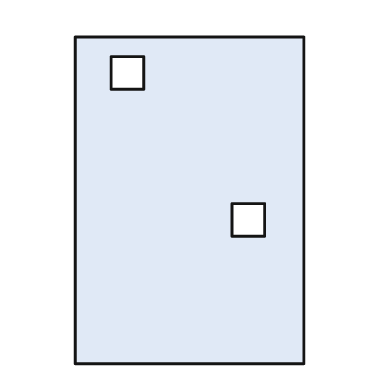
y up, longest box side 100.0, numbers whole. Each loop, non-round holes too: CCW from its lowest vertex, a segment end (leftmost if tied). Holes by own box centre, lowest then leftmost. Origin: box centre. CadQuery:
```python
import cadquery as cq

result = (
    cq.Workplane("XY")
    .moveTo(-35.0, -50.0)
    .lineTo(35.0, -50.0)
    .lineTo(35.0, 50.0)
    .lineTo(-35.0, 50.0)
    .close()
    .moveTo(13.0, -11.0)
    .lineTo(23.0, -11.0)
    .lineTo(23.0, -1.0)
    .lineTo(13.0, -1.0)
    .close()
    .moveTo(-24.0, 34.0)
    .lineTo(-14.0, 34.0)
    .lineTo(-14.0, 44.0)
    .lineTo(-24.0, 44.0)
    .close()
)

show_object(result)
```